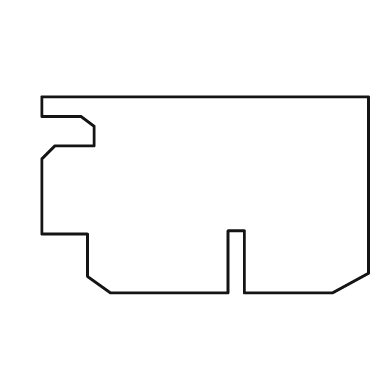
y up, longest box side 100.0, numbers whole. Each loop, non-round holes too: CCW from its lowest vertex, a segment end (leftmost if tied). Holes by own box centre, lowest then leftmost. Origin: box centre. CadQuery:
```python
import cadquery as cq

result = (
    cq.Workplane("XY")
    .moveTo(-29.0, -30.0)
    .lineTo(7.0, -30.0)
    .lineTo(7.0, -11.0)
    .lineTo(12.0, -11.0)
    .lineTo(12.0, -30.0)
    .lineTo(39.0, -30.0)
    .lineTo(50.0, -24.0)
    .lineTo(50.0, 30.0)
    .lineTo(-50.0, 30.0)
    .lineTo(-50.0, 24.0)
    .lineTo(-38.0, 24.0)
    .lineTo(-34.0, 21.0)
    .lineTo(-34.0, 15.0)
    .lineTo(-46.0, 15.0)
    .lineTo(-50.0, 11.0)
    .lineTo(-50.0, -12.0)
    .lineTo(-36.0, -12.0)
    .lineTo(-36.0, -25.0)
    .close()
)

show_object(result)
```